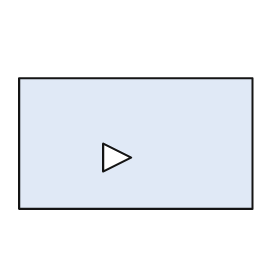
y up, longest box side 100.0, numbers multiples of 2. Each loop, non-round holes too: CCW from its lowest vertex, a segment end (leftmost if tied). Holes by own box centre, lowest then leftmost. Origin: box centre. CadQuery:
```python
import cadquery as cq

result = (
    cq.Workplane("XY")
    .moveTo(-50.0, -28.0)
    .lineTo(50.0, -28.0)
    .lineTo(50.0, 28.0)
    .lineTo(-50.0, 28.0)
    .close()
    .moveTo(-14.0, -12.0)
    .lineTo(-2.0, -6.0)
    .lineTo(-14.0, 0.0)
    .close()
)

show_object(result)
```